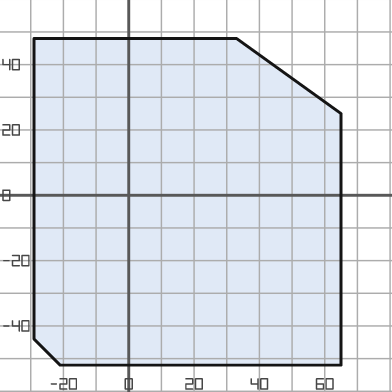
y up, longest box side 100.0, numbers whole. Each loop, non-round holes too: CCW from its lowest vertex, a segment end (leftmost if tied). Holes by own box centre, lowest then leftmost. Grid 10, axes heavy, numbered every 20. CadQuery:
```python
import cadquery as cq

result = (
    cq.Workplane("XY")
    .moveTo(-21.0, -52.0)
    .lineTo(65.0, -52.0)
    .lineTo(65.0, 25.0)
    .lineTo(33.0, 48.0)
    .lineTo(-29.0, 48.0)
    .lineTo(-29.0, -44.0)
    .close()
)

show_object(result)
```